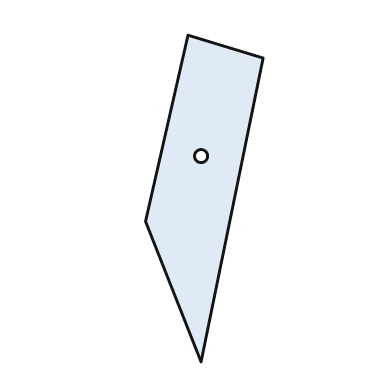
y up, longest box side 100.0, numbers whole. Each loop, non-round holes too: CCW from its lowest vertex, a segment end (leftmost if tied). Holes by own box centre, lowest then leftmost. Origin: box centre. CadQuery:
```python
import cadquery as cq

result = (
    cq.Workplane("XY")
    .moveTo(-1.0, -50.0)
    .lineTo(18.0, 43.0)
    .lineTo(-5.0, 50.0)
    .lineTo(-18.0, -7.0)
    .close()
    .moveTo(-1.0, 13.0)
    .circle(2.0)
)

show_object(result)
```